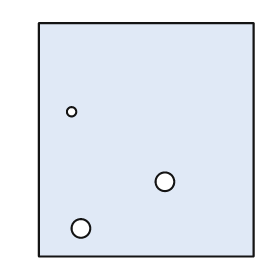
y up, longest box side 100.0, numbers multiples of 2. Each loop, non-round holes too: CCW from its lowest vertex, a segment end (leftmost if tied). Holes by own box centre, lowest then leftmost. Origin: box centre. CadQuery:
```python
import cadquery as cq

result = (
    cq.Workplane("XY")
    .moveTo(-46.0, -50.0)
    .lineTo(46.0, -50.0)
    .lineTo(46.0, 50.0)
    .lineTo(-46.0, 50.0)
    .close()
    .moveTo(-28.0, -38.0)
    .circle(4.0)
    .moveTo(8.0, -18.0)
    .circle(4.0)
    .moveTo(-32.0, 12.0)
    .circle(2.0)
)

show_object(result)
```